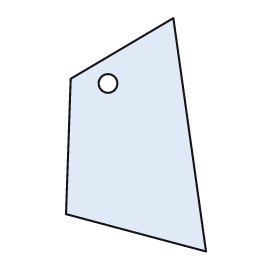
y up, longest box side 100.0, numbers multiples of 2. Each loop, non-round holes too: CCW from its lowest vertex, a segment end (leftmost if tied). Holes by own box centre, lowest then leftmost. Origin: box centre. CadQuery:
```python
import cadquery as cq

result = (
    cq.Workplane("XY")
    .moveTo(30.0, -50.0)
    .lineTo(16.0, 50.0)
    .lineTo(-28.0, 24.0)
    .lineTo(-30.0, -34.0)
    .close()
    .moveTo(-12.0, 22.0)
    .circle(4.0)
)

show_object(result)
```